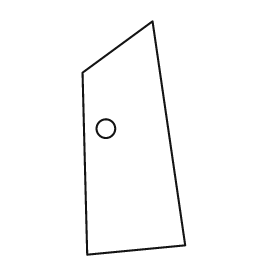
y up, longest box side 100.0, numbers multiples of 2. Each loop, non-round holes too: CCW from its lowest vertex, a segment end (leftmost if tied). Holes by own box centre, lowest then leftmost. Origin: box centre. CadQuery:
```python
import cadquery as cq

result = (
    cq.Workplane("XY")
    .moveTo(-20.0, -50.0)
    .lineTo(22.0, -46.0)
    .lineTo(8.0, 50.0)
    .lineTo(-22.0, 28.0)
    .close()
    .moveTo(-12.0, 4.0)
    .circle(4.0)
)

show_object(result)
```